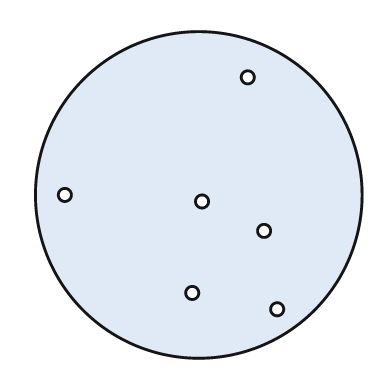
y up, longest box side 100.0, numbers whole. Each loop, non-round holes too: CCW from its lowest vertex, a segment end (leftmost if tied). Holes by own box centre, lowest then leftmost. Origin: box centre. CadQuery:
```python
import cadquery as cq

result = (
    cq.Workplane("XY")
    .moveTo(0.0, 0.0)
    .circle(50.0)
    .moveTo(24.0, -35.0)
    .circle(2.0)
    .moveTo(-2.0, -30.0)
    .circle(2.0)
    .moveTo(20.0, -11.0)
    .circle(2.0)
    .moveTo(1.0, -2.0)
    .circle(2.0)
    .moveTo(-41.0, 0.0)
    .circle(2.0)
    .moveTo(15.0, 36.0)
    .circle(2.0)
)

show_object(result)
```